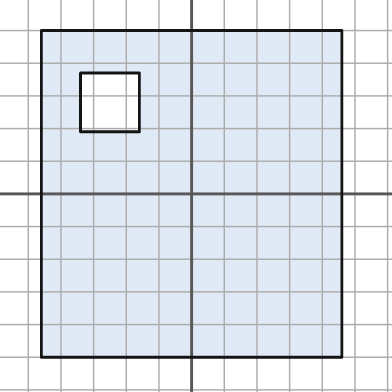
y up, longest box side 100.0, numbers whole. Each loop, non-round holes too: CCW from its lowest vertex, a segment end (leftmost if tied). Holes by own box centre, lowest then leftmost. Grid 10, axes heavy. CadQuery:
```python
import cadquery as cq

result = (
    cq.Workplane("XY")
    .moveTo(-46.0, -50.0)
    .lineTo(46.0, -50.0)
    .lineTo(46.0, 50.0)
    .lineTo(-46.0, 50.0)
    .close()
    .moveTo(-34.0, 19.0)
    .lineTo(-16.0, 19.0)
    .lineTo(-16.0, 37.0)
    .lineTo(-34.0, 37.0)
    .close()
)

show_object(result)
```